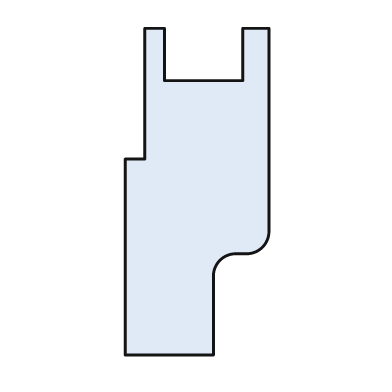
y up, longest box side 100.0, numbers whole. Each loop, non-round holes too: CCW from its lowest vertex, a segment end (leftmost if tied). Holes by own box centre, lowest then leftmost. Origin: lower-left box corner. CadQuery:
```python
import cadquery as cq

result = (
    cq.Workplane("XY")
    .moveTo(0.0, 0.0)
    .lineTo(27.0, 0.0)
    .lineTo(27.0, 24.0)
    .threePointArc((29.0, 29.0), (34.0, 31.0))
    .lineTo(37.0, 31.0)
    .threePointArc((42.0, 33.0), (44.0, 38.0))
    .lineTo(44.0, 100.0)
    .lineTo(36.0, 100.0)
    .lineTo(36.0, 84.0)
    .lineTo(12.0, 84.0)
    .lineTo(12.0, 100.0)
    .lineTo(6.0, 100.0)
    .lineTo(6.0, 60.0)
    .lineTo(0.0, 60.0)
    .close()
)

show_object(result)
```